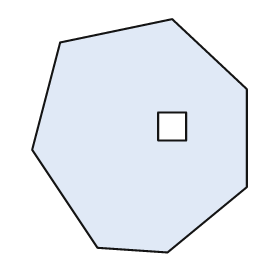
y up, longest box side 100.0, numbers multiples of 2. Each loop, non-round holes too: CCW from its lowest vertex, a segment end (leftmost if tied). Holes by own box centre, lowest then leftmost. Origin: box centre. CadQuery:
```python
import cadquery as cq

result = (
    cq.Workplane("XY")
    .moveTo(12.0, -50.0)
    .lineTo(46.0, -22.0)
    .lineTo(46.0, 20.0)
    .lineTo(14.0, 50.0)
    .lineTo(-34.0, 40.0)
    .lineTo(-46.0, -6.0)
    .lineTo(-18.0, -48.0)
    .close()
    .moveTo(8.0, -2.0)
    .lineTo(20.0, -2.0)
    .lineTo(20.0, 10.0)
    .lineTo(8.0, 10.0)
    .close()
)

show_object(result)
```